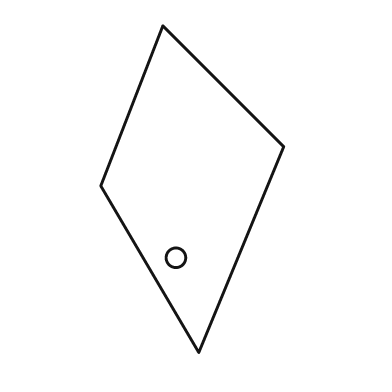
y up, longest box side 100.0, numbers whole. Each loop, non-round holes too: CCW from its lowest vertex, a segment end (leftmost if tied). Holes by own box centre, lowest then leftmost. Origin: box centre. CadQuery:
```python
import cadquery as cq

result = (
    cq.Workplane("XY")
    .moveTo(2.0, -50.0)
    .lineTo(28.0, 13.0)
    .lineTo(-9.0, 50.0)
    .lineTo(-28.0, 1.0)
    .close()
    .moveTo(-5.0, -21.0)
    .circle(3.0)
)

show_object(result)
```